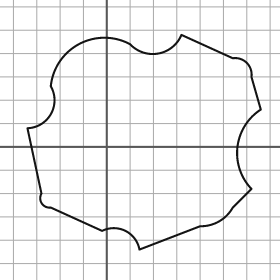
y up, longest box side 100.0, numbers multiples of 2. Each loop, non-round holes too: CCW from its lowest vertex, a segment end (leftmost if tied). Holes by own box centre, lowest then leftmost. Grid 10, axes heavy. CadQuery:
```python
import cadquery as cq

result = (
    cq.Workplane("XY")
    .moveTo(14.0, -44.0)
    .lineTo(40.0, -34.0)
    .threePointArc((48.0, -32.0), (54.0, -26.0))
    .lineTo(62.0, -18.0)
    .threePointArc((56.0, 0.0), (66.0, 16.0))
    .lineTo(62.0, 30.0)
    .threePointArc((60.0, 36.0), (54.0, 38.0))
    .lineTo(32.0, 48.0)
    .threePointArc((22.0, 40.0), (10.0, 44.0))
    .threePointArc((-12.0, 44.0), (-24.0, 26.0))
    .threePointArc((-24.0, 14.0), (-34.0, 8.0))
    .lineTo(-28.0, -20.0)
    .threePointArc((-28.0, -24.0), (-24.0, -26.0))
    .lineTo(-2.0, -36.0)
    .threePointArc((8.0, -36.0), (14.0, -44.0))
    .close()
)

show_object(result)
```